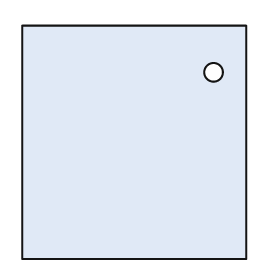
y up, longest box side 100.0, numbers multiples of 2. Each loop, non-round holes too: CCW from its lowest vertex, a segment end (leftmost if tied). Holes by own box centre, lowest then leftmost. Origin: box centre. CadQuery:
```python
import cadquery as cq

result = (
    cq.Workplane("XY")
    .moveTo(-48.0, -50.0)
    .lineTo(48.0, -50.0)
    .lineTo(48.0, 50.0)
    .lineTo(-48.0, 50.0)
    .close()
    .moveTo(34.0, 30.0)
    .circle(4.0)
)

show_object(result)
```